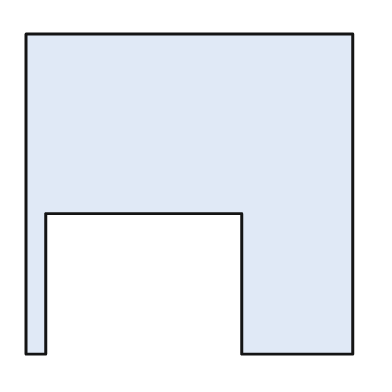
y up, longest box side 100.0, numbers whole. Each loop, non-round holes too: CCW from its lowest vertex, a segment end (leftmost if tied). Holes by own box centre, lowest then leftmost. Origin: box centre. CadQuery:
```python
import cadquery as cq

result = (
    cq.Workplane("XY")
    .moveTo(-50.0, -49.0)
    .lineTo(-44.0, -49.0)
    .lineTo(-44.0, -6.0)
    .lineTo(16.0, -6.0)
    .lineTo(16.0, -49.0)
    .lineTo(50.0, -49.0)
    .lineTo(50.0, 49.0)
    .lineTo(-50.0, 49.0)
    .close()
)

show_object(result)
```